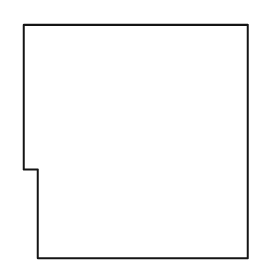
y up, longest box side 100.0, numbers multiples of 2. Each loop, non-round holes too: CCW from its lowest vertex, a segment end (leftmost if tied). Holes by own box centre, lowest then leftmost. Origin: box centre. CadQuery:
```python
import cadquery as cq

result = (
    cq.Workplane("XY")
    .moveTo(-42.0, -50.0)
    .lineTo(48.0, -50.0)
    .lineTo(48.0, 50.0)
    .lineTo(-48.0, 50.0)
    .lineTo(-48.0, -12.0)
    .lineTo(-42.0, -12.0)
    .close()
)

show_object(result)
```